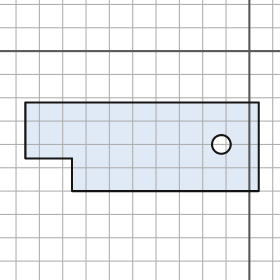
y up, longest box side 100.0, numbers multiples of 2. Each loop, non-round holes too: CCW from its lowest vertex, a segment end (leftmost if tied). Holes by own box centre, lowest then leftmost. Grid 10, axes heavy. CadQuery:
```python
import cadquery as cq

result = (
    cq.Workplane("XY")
    .moveTo(-76.0, -60.0)
    .lineTo(4.0, -60.0)
    .lineTo(4.0, -22.0)
    .lineTo(-96.0, -22.0)
    .lineTo(-96.0, -46.0)
    .lineTo(-76.0, -46.0)
    .close()
    .moveTo(-12.0, -40.0)
    .circle(4.0)
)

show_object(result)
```